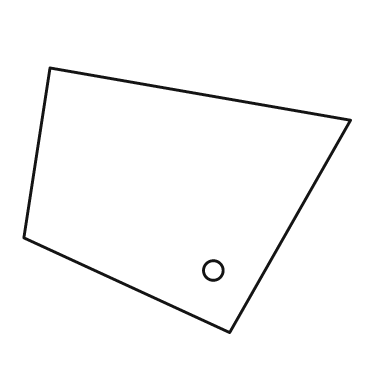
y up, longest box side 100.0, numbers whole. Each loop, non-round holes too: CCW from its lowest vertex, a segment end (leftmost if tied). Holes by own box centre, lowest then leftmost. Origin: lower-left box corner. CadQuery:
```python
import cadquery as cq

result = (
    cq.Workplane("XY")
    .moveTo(63.0, 0.0)
    .lineTo(100.0, 65.0)
    .lineTo(8.0, 81.0)
    .lineTo(0.0, 29.0)
    .close()
    .moveTo(58.0, 19.0)
    .circle(3.0)
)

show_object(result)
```